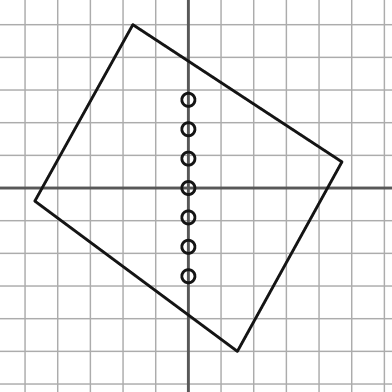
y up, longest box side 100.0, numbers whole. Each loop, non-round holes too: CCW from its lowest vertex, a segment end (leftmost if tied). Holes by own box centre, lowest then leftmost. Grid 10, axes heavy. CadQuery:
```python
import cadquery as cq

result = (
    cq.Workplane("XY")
    .moveTo(15.0, -50.0)
    .lineTo(47.0, 8.0)
    .lineTo(-17.0, 50.0)
    .lineTo(-47.0, -4.0)
    .close()
    .moveTo(0.0, -27.0)
    .circle(2.0)
    .moveTo(0.0, -18.0)
    .circle(2.0)
    .moveTo(0.0, -9.0)
    .circle(2.0)
    .moveTo(0.0, 0.0)
    .circle(2.0)
    .moveTo(0.0, 9.0)
    .circle(2.0)
    .moveTo(0.0, 18.0)
    .circle(2.0)
    .moveTo(0.0, 27.0)
    .circle(2.0)
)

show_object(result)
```